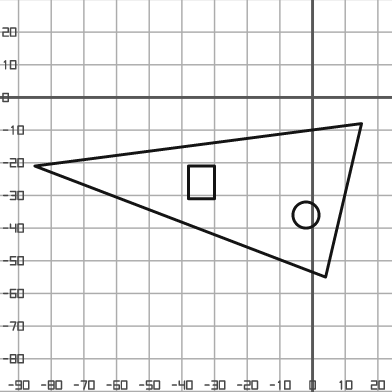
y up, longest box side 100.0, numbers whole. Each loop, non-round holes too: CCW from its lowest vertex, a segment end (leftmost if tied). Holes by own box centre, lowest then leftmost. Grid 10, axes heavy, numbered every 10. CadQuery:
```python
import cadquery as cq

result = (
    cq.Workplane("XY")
    .moveTo(4.0, -55.0)
    .lineTo(15.0, -8.0)
    .lineTo(-85.0, -21.0)
    .close()
    .moveTo(-2.0, -36.0)
    .circle(4.0)
    .moveTo(-38.0, -31.0)
    .lineTo(-30.0, -31.0)
    .lineTo(-30.0, -21.0)
    .lineTo(-38.0, -21.0)
    .close()
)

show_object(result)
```